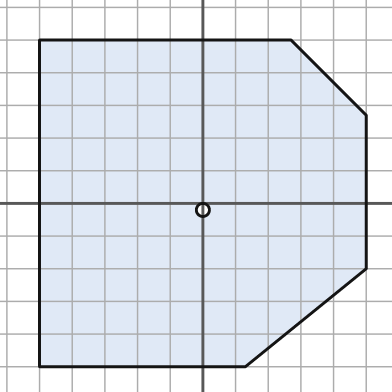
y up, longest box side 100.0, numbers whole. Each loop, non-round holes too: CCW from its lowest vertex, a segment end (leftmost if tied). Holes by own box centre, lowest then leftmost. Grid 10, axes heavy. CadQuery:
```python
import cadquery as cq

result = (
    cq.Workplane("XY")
    .moveTo(-50.0, -50.0)
    .lineTo(13.0, -50.0)
    .lineTo(50.0, -20.0)
    .lineTo(50.0, 27.0)
    .lineTo(27.0, 50.0)
    .lineTo(-50.0, 50.0)
    .close()
    .moveTo(0.0, -2.0)
    .circle(2.0)
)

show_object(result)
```